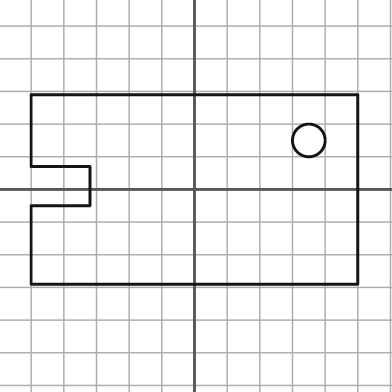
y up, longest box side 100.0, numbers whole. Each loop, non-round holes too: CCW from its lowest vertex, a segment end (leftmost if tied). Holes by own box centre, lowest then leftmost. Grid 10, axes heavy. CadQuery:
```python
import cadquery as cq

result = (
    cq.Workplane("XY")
    .moveTo(-50.0, -29.0)
    .lineTo(50.0, -29.0)
    .lineTo(50.0, 29.0)
    .lineTo(-50.0, 29.0)
    .lineTo(-50.0, 7.0)
    .lineTo(-32.0, 7.0)
    .lineTo(-32.0, -5.0)
    .lineTo(-50.0, -5.0)
    .close()
    .moveTo(35.0, 15.0)
    .circle(5.0)
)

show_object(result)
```